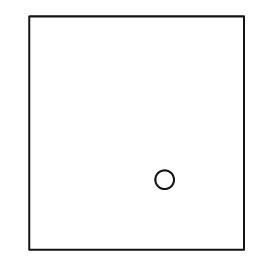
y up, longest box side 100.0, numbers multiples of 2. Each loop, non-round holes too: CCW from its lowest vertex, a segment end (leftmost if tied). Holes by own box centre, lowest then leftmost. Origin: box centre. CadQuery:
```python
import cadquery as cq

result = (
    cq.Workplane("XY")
    .moveTo(-46.0, -50.0)
    .lineTo(46.0, -50.0)
    .lineTo(46.0, 50.0)
    .lineTo(-46.0, 50.0)
    .close()
    .moveTo(12.0, -20.0)
    .circle(4.0)
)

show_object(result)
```